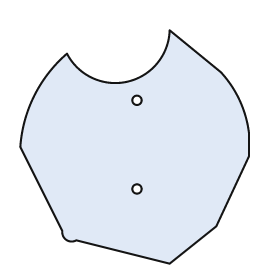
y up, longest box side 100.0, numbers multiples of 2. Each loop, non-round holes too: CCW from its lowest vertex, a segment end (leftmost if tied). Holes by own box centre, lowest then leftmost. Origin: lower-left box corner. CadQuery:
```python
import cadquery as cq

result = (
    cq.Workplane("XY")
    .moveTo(64.0, 0.0)
    .lineTo(84.0, 16.0)
    .lineTo(98.0, 46.0)
    .lineTo(98.0, 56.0)
    .threePointArc((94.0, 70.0), (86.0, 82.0))
    .lineTo(64.0, 100.0)
    .threePointArc((46.0, 78.0), (20.0, 90.0))
    .threePointArc((6.0, 72.0), (0.0, 50.0))
    .lineTo(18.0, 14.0)
    .threePointArc((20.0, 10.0), (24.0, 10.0))
    .close()
    .moveTo(50.0, 32.0)
    .circle(2.0)
    .moveTo(50.0, 70.0)
    .circle(2.0)
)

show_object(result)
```